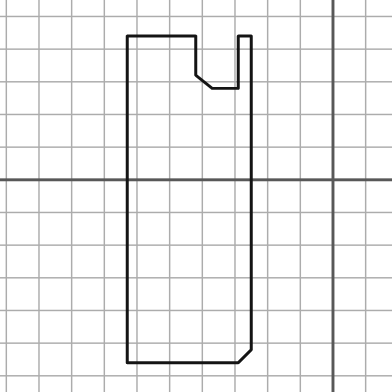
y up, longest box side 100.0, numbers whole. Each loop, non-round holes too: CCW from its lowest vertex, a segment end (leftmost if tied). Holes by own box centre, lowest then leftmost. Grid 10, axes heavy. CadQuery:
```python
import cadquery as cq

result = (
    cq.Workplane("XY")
    .moveTo(-63.0, -56.0)
    .lineTo(-29.0, -56.0)
    .lineTo(-25.0, -52.0)
    .lineTo(-25.0, 44.0)
    .lineTo(-29.0, 44.0)
    .lineTo(-29.0, 28.0)
    .lineTo(-37.0, 28.0)
    .lineTo(-42.0, 32.0)
    .lineTo(-42.0, 44.0)
    .lineTo(-63.0, 44.0)
    .close()
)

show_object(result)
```